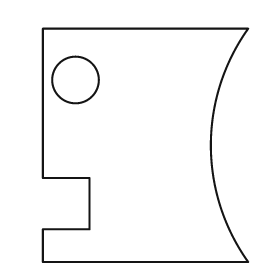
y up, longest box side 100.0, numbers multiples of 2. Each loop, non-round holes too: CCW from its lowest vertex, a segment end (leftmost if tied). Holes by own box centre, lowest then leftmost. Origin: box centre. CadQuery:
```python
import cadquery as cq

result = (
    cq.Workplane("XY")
    .moveTo(-44.0, -50.0)
    .lineTo(44.0, -50.0)
    .threePointArc((28.0, 0.0), (44.0, 50.0))
    .lineTo(-44.0, 50.0)
    .lineTo(-44.0, -14.0)
    .lineTo(-24.0, -14.0)
    .lineTo(-24.0, -36.0)
    .lineTo(-44.0, -36.0)
    .close()
    .moveTo(-30.0, 28.0)
    .circle(10.0)
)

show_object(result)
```